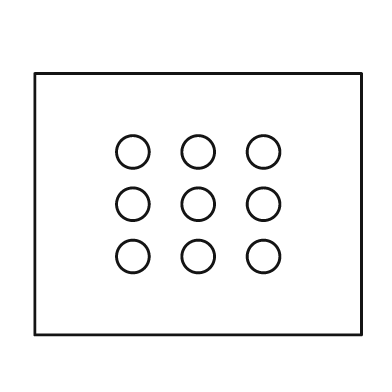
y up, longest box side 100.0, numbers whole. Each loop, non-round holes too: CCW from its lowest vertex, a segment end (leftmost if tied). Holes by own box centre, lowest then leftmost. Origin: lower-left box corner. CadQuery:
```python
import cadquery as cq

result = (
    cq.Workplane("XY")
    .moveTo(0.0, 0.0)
    .lineTo(100.0, 0.0)
    .lineTo(100.0, 80.0)
    .lineTo(0.0, 80.0)
    .close()
    .moveTo(30.0, 24.0)
    .circle(5.0)
    .moveTo(50.0, 24.0)
    .circle(5.0)
    .moveTo(70.0, 24.0)
    .circle(5.0)
    .moveTo(30.0, 40.0)
    .circle(5.0)
    .moveTo(50.0, 40.0)
    .circle(5.0)
    .moveTo(70.0, 40.0)
    .circle(5.0)
    .moveTo(30.0, 56.0)
    .circle(5.0)
    .moveTo(50.0, 56.0)
    .circle(5.0)
    .moveTo(70.0, 56.0)
    .circle(5.0)
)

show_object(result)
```